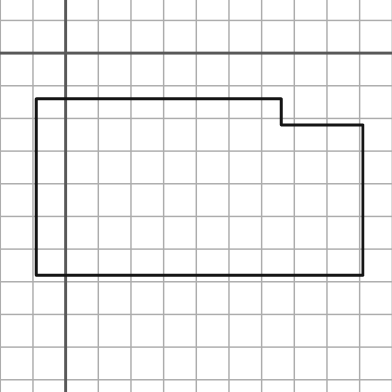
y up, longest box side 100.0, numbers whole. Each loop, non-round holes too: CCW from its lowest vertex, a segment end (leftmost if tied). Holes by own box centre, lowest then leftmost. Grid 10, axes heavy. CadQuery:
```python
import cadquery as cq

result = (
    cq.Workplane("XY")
    .moveTo(-9.0, -68.0)
    .lineTo(91.0, -68.0)
    .lineTo(91.0, -22.0)
    .lineTo(66.0, -22.0)
    .lineTo(66.0, -14.0)
    .lineTo(-9.0, -14.0)
    .close()
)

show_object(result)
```